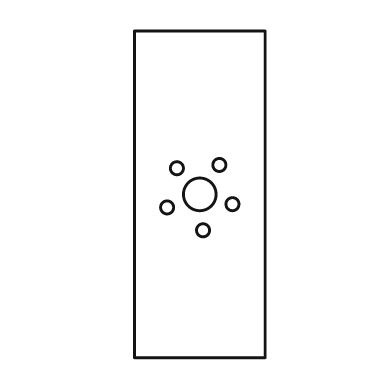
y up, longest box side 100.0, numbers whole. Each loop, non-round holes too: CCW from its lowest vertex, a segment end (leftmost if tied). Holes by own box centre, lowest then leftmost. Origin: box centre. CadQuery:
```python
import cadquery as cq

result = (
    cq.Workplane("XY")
    .moveTo(-20.0, -50.0)
    .lineTo(20.0, -50.0)
    .lineTo(20.0, 50.0)
    .lineTo(-20.0, 50.0)
    .close()
    .moveTo(1.0, -11.0)
    .circle(2.0)
    .moveTo(-10.0, -4.0)
    .circle(2.0)
    .moveTo(10.0, -3.0)
    .circle(2.0)
    .moveTo(0.0, 0.0)
    .circle(5.0)
    .moveTo(-7.0, 8.0)
    .circle(2.0)
    .moveTo(6.0, 9.0)
    .circle(2.0)
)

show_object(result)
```